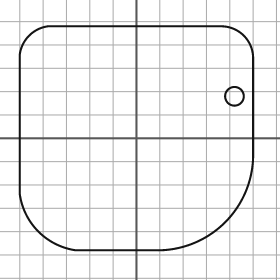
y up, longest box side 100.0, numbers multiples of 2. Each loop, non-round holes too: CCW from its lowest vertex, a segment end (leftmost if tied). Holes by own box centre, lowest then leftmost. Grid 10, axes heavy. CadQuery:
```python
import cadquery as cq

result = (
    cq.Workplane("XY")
    .moveTo(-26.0, -48.0)
    .lineTo(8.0, -48.0)
    .threePointArc((38.0, -36.0), (50.0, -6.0))
    .lineTo(50.0, 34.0)
    .threePointArc((46.0, 44.0), (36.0, 48.0))
    .lineTo(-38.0, 48.0)
    .threePointArc((-46.0, 44.0), (-50.0, 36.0))
    .lineTo(-50.0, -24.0)
    .threePointArc((-42.0, -40.0), (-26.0, -48.0))
    .close()
    .moveTo(42.0, 18.0)
    .circle(4.0)
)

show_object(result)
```